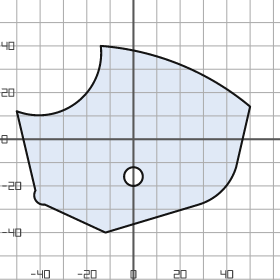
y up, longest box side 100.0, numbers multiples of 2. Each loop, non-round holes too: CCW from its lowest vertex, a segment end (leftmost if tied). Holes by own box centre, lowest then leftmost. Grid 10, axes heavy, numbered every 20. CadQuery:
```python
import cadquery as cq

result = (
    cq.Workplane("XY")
    .moveTo(-12.0, -40.0)
    .lineTo(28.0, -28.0)
    .threePointArc((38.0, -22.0), (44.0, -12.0))
    .lineTo(50.0, 14.0)
    .threePointArc((20.0, 32.0), (-14.0, 40.0))
    .threePointArc((-24.0, 16.0), (-50.0, 12.0))
    .lineTo(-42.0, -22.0)
    .threePointArc((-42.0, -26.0), (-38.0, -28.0))
    .close()
    .moveTo(0.0, -16.0)
    .circle(4.0)
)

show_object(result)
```